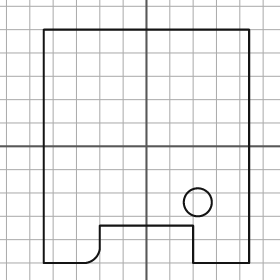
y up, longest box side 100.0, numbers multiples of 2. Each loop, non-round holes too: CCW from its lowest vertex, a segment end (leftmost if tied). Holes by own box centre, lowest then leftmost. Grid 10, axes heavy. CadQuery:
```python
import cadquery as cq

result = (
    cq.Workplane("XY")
    .moveTo(-44.0, -50.0)
    .lineTo(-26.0, -50.0)
    .threePointArc((-22.0, -48.0), (-20.0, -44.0))
    .lineTo(-20.0, -34.0)
    .lineTo(20.0, -34.0)
    .lineTo(20.0, -50.0)
    .lineTo(44.0, -50.0)
    .lineTo(44.0, 50.0)
    .lineTo(-44.0, 50.0)
    .close()
    .moveTo(22.0, -24.0)
    .circle(6.0)
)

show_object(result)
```